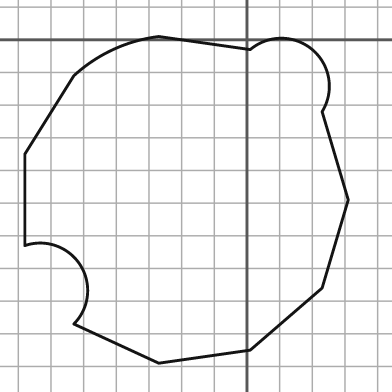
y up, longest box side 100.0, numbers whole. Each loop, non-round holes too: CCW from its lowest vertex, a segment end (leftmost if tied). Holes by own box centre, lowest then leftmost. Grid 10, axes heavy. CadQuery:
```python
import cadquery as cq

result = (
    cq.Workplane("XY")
    .moveTo(-27.0, -99.0)
    .lineTo(1.0, -95.0)
    .lineTo(23.0, -76.0)
    .lineTo(31.0, -49.0)
    .lineTo(23.0, -22.0)
    .threePointArc((20.0, -3.0), (1.0, -3.0))
    .lineTo(-27.0, 1.0)
    .threePointArc((-41.0, -3.0), (-53.0, -11.0))
    .lineTo(-68.0, -35.0)
    .lineTo(-68.0, -63.0)
    .threePointArc((-51.0, -69.0), (-53.0, -87.0))
    .close()
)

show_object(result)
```